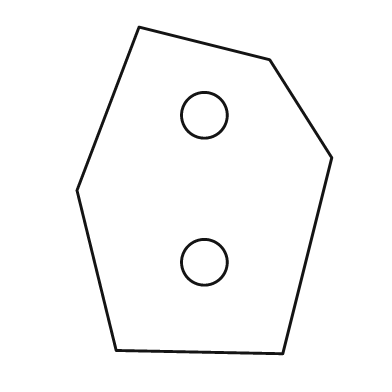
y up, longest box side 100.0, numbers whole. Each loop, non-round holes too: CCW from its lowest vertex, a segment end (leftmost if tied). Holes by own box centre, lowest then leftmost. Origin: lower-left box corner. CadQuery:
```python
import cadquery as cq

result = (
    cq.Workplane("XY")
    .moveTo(63.0, 0.0)
    .lineTo(78.0, 60.0)
    .lineTo(59.0, 90.0)
    .lineTo(19.0, 100.0)
    .lineTo(0.0, 50.0)
    .lineTo(12.0, 1.0)
    .close()
    .moveTo(39.0, 28.0)
    .circle(7.0)
    .moveTo(39.0, 73.0)
    .circle(7.0)
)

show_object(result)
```